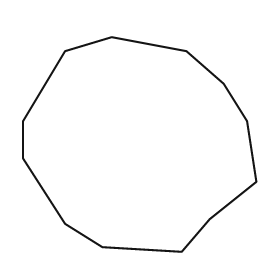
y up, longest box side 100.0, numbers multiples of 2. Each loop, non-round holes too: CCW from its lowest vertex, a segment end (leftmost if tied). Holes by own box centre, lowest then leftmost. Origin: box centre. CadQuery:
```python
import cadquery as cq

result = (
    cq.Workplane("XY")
    .moveTo(18.0, -46.0)
    .lineTo(30.0, -32.0)
    .lineTo(50.0, -16.0)
    .lineTo(46.0, 10.0)
    .lineTo(36.0, 26.0)
    .lineTo(20.0, 40.0)
    .lineTo(-12.0, 46.0)
    .lineTo(-32.0, 40.0)
    .lineTo(-50.0, 10.0)
    .lineTo(-50.0, -6.0)
    .lineTo(-32.0, -34.0)
    .lineTo(-16.0, -44.0)
    .close()
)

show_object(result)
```